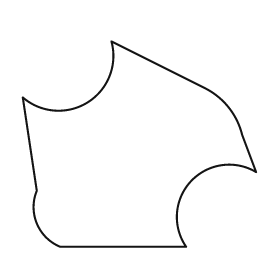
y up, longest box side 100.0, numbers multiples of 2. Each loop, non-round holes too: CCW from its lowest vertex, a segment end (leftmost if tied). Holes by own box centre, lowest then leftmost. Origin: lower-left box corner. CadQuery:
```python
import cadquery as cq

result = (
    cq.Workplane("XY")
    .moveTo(16.0, 0.0)
    .lineTo(70.0, 0.0)
    .threePointArc((72.0, 28.0), (100.0, 32.0))
    .lineTo(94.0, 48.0)
    .threePointArc((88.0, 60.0), (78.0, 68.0))
    .lineTo(38.0, 88.0)
    .threePointArc((28.0, 62.0), (0.0, 64.0))
    .lineTo(6.0, 24.0)
    .threePointArc((6.0, 10.0), (16.0, 0.0))
    .close()
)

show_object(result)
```